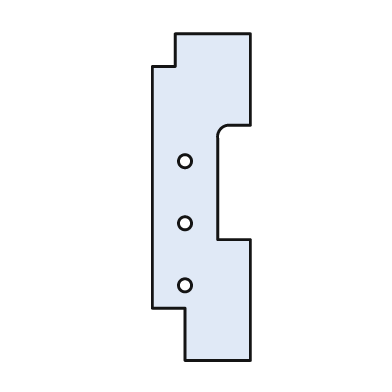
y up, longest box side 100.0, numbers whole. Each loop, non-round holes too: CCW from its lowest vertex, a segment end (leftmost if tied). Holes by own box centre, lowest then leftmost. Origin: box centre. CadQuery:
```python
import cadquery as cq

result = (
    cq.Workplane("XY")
    .moveTo(-5.0, -50.0)
    .lineTo(15.0, -50.0)
    .lineTo(15.0, -13.0)
    .lineTo(5.0, -13.0)
    .lineTo(5.0, 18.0)
    .threePointArc((6.0, 21.0), (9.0, 22.0))
    .lineTo(15.0, 22.0)
    .lineTo(15.0, 50.0)
    .lineTo(-8.0, 50.0)
    .lineTo(-8.0, 40.0)
    .lineTo(-15.0, 40.0)
    .lineTo(-15.0, -34.0)
    .lineTo(-5.0, -34.0)
    .close()
    .moveTo(-5.0, -27.0)
    .circle(2.0)
    .moveTo(-5.0, -8.0)
    .circle(2.0)
    .moveTo(-5.0, 11.0)
    .circle(2.0)
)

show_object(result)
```